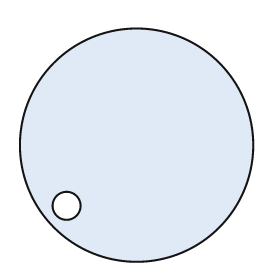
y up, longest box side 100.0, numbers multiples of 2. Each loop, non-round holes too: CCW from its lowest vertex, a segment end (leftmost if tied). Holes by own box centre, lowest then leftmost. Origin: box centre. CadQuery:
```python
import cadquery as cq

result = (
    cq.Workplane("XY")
    .moveTo(0.0, 0.0)
    .circle(50.0)
    .moveTo(-30.0, -26.0)
    .circle(6.0)
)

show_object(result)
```